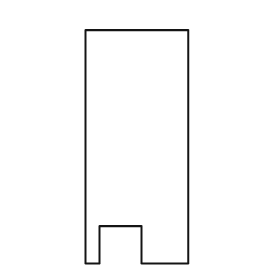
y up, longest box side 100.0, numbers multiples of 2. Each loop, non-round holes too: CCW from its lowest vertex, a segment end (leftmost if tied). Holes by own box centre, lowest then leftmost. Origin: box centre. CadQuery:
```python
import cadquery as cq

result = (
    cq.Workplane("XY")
    .moveTo(-22.0, -50.0)
    .lineTo(-16.0, -50.0)
    .lineTo(-16.0, -34.0)
    .lineTo(2.0, -34.0)
    .lineTo(2.0, -50.0)
    .lineTo(22.0, -50.0)
    .lineTo(22.0, 50.0)
    .lineTo(-22.0, 50.0)
    .close()
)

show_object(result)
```